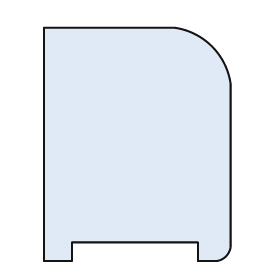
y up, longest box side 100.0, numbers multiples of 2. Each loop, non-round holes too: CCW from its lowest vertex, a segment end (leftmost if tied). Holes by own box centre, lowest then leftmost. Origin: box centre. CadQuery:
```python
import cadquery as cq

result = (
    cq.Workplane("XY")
    .moveTo(-40.0, -50.0)
    .lineTo(-28.0, -50.0)
    .lineTo(-28.0, -42.0)
    .lineTo(26.0, -42.0)
    .lineTo(26.0, -50.0)
    .lineTo(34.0, -50.0)
    .threePointArc((38.0, -48.0), (40.0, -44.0))
    .lineTo(40.0, 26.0)
    .threePointArc((32.0, 42.0), (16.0, 50.0))
    .lineTo(-40.0, 50.0)
    .close()
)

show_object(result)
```